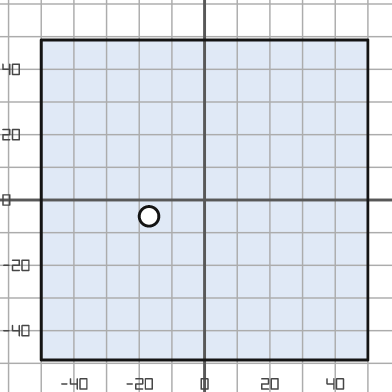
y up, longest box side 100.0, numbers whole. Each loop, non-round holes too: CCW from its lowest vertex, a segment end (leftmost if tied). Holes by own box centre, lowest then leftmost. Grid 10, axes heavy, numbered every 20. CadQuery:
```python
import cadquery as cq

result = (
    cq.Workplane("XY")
    .moveTo(-50.0, -49.0)
    .lineTo(50.0, -49.0)
    .lineTo(50.0, 49.0)
    .lineTo(-50.0, 49.0)
    .close()
    .moveTo(-17.0, -5.0)
    .circle(3.0)
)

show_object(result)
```